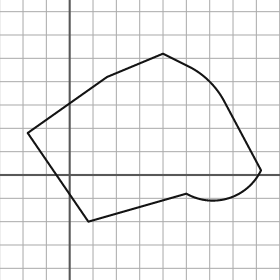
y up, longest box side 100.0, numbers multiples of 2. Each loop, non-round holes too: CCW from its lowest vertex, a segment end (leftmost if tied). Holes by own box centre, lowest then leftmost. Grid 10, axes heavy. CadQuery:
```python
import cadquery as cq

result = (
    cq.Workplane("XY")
    .moveTo(8.0, -20.0)
    .lineTo(50.0, -8.0)
    .threePointArc((68.0, -10.0), (82.0, 2.0))
    .lineTo(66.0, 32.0)
    .threePointArc((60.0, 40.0), (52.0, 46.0))
    .lineTo(40.0, 52.0)
    .lineTo(16.0, 42.0)
    .lineTo(-18.0, 18.0)
    .close()
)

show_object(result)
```